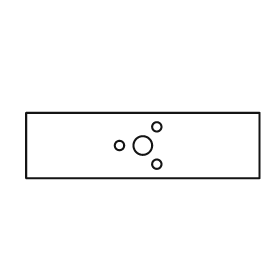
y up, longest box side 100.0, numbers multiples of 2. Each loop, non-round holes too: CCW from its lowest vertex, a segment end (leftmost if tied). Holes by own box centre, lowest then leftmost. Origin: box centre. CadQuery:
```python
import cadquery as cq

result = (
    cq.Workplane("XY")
    .moveTo(-50.0, -14.0)
    .lineTo(50.0, -14.0)
    .lineTo(50.0, 14.0)
    .lineTo(-50.0, 14.0)
    .close()
    .moveTo(6.0, -8.0)
    .circle(2.0)
    .moveTo(-10.0, 0.0)
    .circle(2.0)
    .moveTo(0.0, 0.0)
    .circle(4.0)
    .moveTo(6.0, 8.0)
    .circle(2.0)
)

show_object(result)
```